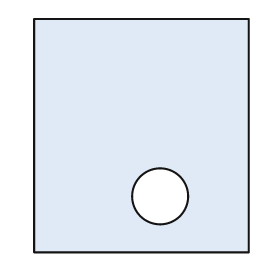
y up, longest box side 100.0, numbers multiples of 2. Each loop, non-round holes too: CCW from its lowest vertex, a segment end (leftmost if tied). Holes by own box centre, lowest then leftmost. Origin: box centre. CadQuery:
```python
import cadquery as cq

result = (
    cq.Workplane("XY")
    .moveTo(-46.0, -50.0)
    .lineTo(46.0, -50.0)
    .lineTo(46.0, 50.0)
    .lineTo(-46.0, 50.0)
    .close()
    .moveTo(8.0, -26.0)
    .circle(12.0)
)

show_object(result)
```